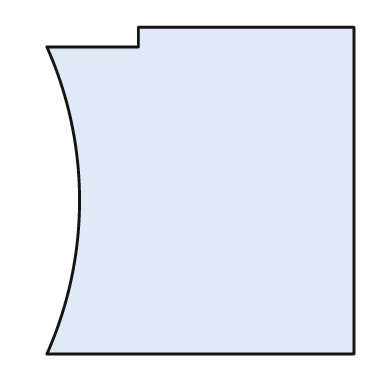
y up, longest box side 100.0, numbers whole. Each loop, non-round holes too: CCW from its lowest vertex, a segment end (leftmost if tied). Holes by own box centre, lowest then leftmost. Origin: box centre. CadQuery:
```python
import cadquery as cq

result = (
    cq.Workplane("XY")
    .moveTo(-47.0, -50.0)
    .lineTo(47.0, -50.0)
    .lineTo(47.0, 50.0)
    .lineTo(-19.0, 50.0)
    .lineTo(-19.0, 44.0)
    .lineTo(-47.0, 44.0)
    .threePointArc((-37.0, -3.0), (-47.0, -50.0))
    .close()
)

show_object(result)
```